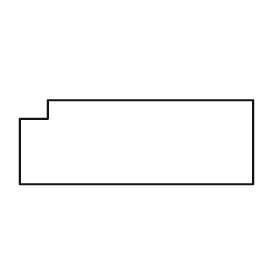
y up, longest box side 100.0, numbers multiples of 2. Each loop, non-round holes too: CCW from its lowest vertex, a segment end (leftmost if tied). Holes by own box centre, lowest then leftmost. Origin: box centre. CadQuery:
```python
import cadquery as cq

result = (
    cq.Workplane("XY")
    .moveTo(-50.0, -18.0)
    .lineTo(50.0, -18.0)
    .lineTo(50.0, 18.0)
    .lineTo(-38.0, 18.0)
    .lineTo(-38.0, 10.0)
    .lineTo(-50.0, 10.0)
    .close()
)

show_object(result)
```